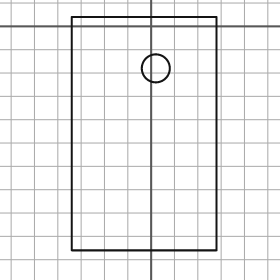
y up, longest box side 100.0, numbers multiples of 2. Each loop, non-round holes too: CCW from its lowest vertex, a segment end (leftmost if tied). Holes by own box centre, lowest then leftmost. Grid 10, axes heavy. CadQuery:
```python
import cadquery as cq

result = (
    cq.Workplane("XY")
    .moveTo(-34.0, -96.0)
    .lineTo(28.0, -96.0)
    .lineTo(28.0, 4.0)
    .lineTo(-34.0, 4.0)
    .close()
    .moveTo(2.0, -18.0)
    .circle(6.0)
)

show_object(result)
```